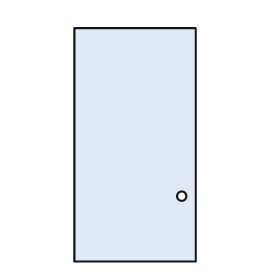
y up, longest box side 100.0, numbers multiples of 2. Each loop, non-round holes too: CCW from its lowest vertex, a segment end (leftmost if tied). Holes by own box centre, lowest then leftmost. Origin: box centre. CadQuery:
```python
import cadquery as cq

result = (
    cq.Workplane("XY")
    .moveTo(-26.0, -50.0)
    .lineTo(26.0, -50.0)
    .lineTo(26.0, 50.0)
    .lineTo(-26.0, 50.0)
    .close()
    .moveTo(20.0, -22.0)
    .circle(2.0)
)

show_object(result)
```